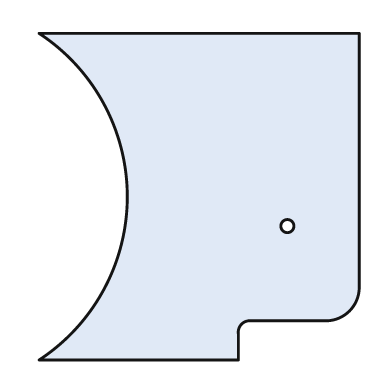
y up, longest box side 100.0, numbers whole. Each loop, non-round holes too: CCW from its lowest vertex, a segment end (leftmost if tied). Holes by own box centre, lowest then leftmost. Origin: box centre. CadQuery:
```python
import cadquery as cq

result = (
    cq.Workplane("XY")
    .moveTo(-49.0, -50.0)
    .lineTo(12.0, -50.0)
    .lineTo(12.0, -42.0)
    .threePointArc((13.0, -39.0), (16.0, -38.0))
    .lineTo(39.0, -38.0)
    .threePointArc((46.0, -35.0), (49.0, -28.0))
    .lineTo(49.0, 50.0)
    .lineTo(-49.0, 50.0)
    .threePointArc((-22.0, 0.0), (-49.0, -50.0))
    .close()
    .moveTo(27.0, -9.0)
    .circle(2.0)
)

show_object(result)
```